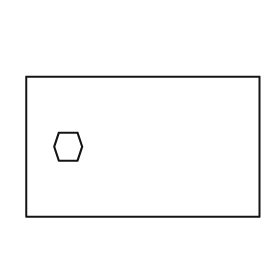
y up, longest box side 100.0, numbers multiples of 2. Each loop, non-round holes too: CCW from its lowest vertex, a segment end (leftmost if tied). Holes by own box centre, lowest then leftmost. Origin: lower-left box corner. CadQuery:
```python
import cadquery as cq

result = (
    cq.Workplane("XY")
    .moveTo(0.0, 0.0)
    .lineTo(100.0, 0.0)
    .lineTo(100.0, 60.0)
    .lineTo(0.0, 60.0)
    .close()
    .moveTo(14.0, 24.0)
    .lineTo(22.0, 24.0)
    .lineTo(24.0, 30.0)
    .lineTo(22.0, 36.0)
    .lineTo(14.0, 36.0)
    .lineTo(12.0, 30.0)
    .close()
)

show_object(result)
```